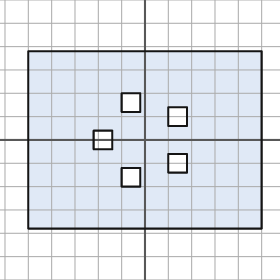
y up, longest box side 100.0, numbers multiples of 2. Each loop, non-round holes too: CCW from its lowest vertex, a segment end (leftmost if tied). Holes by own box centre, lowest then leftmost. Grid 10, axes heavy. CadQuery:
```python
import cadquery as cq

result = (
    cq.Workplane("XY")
    .moveTo(-50.0, -38.0)
    .lineTo(50.0, -38.0)
    .lineTo(50.0, 38.0)
    .lineTo(-50.0, 38.0)
    .close()
    .moveTo(-10.0, -20.0)
    .lineTo(-2.0, -20.0)
    .lineTo(-2.0, -12.0)
    .lineTo(-10.0, -12.0)
    .close()
    .moveTo(10.0, -14.0)
    .lineTo(18.0, -14.0)
    .lineTo(18.0, -6.0)
    .lineTo(10.0, -6.0)
    .close()
    .moveTo(-22.0, -4.0)
    .lineTo(-14.0, -4.0)
    .lineTo(-14.0, 4.0)
    .lineTo(-22.0, 4.0)
    .close()
    .moveTo(10.0, 6.0)
    .lineTo(18.0, 6.0)
    .lineTo(18.0, 14.0)
    .lineTo(10.0, 14.0)
    .close()
    .moveTo(-10.0, 12.0)
    .lineTo(-2.0, 12.0)
    .lineTo(-2.0, 20.0)
    .lineTo(-10.0, 20.0)
    .close()
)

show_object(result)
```